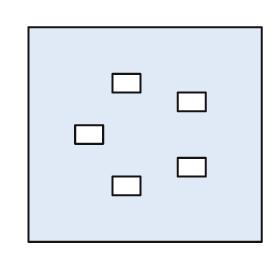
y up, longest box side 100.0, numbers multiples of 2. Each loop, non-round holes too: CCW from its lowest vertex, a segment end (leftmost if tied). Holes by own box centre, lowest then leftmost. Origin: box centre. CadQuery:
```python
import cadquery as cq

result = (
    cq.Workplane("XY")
    .moveTo(-50.0, -46.0)
    .lineTo(50.0, -46.0)
    .lineTo(50.0, 46.0)
    .lineTo(-50.0, 46.0)
    .close()
    .moveTo(-14.0, -26.0)
    .lineTo(-2.0, -26.0)
    .lineTo(-2.0, -18.0)
    .lineTo(-14.0, -18.0)
    .close()
    .moveTo(14.0, -18.0)
    .lineTo(26.0, -18.0)
    .lineTo(26.0, -10.0)
    .lineTo(14.0, -10.0)
    .close()
    .moveTo(-30.0, -4.0)
    .lineTo(-18.0, -4.0)
    .lineTo(-18.0, 4.0)
    .lineTo(-30.0, 4.0)
    .close()
    .moveTo(14.0, 10.0)
    .lineTo(26.0, 10.0)
    .lineTo(26.0, 18.0)
    .lineTo(14.0, 18.0)
    .close()
    .moveTo(-14.0, 18.0)
    .lineTo(-2.0, 18.0)
    .lineTo(-2.0, 26.0)
    .lineTo(-14.0, 26.0)
    .close()
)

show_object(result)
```